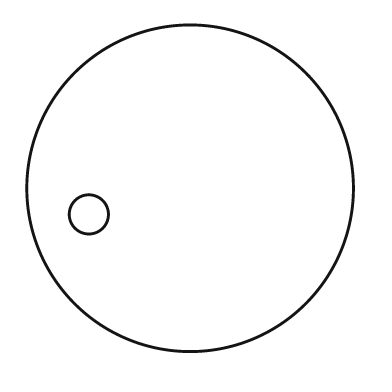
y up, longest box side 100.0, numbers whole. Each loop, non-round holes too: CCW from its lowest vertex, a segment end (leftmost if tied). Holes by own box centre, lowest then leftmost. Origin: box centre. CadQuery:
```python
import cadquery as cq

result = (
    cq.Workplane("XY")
    .moveTo(0.0, 0.0)
    .circle(50.0)
    .moveTo(-31.0, -8.0)
    .circle(6.0)
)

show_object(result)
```